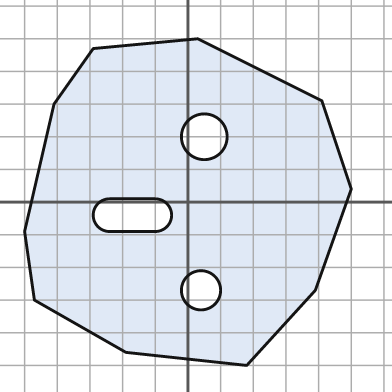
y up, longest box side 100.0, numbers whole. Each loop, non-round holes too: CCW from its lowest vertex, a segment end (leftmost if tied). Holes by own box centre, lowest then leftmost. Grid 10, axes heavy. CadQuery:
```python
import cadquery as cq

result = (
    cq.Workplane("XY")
    .moveTo(18.0, -50.0)
    .lineTo(39.0, -27.0)
    .lineTo(50.0, 4.0)
    .lineTo(41.0, 31.0)
    .lineTo(3.0, 50.0)
    .lineTo(-29.0, 47.0)
    .lineTo(-41.0, 30.0)
    .lineTo(-50.0, -9.0)
    .lineTo(-47.0, -30.0)
    .lineTo(-19.0, -46.0)
    .close()
    .moveTo(4.0, -27.0)
    .circle(6.0)
    .moveTo(-24.0, -9.0)
    .lineTo(-10.0, -9.0)
    .threePointArc((-5.0, -4.0), (-10.0, 1.0))
    .lineTo(-24.0, 1.0)
    .threePointArc((-29.0, -4.0), (-24.0, -9.0))
    .close()
    .moveTo(5.0, 20.0)
    .circle(7.0)
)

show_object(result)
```